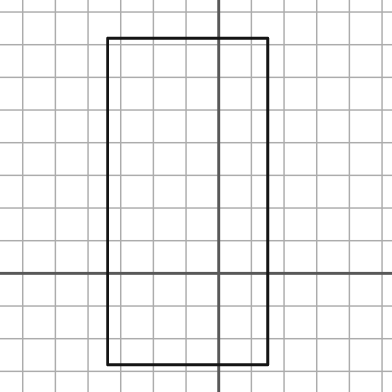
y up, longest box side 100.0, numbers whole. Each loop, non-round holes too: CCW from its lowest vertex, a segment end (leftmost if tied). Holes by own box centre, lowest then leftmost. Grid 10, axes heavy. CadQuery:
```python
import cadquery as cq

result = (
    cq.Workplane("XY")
    .moveTo(-34.0, -28.0)
    .lineTo(15.0, -28.0)
    .lineTo(15.0, 72.0)
    .lineTo(-34.0, 72.0)
    .close()
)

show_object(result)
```